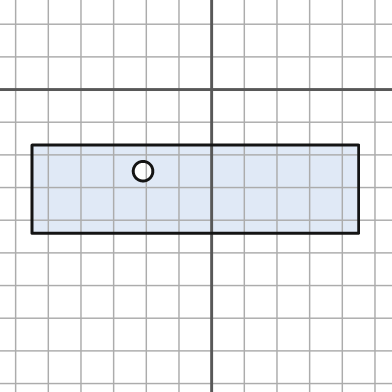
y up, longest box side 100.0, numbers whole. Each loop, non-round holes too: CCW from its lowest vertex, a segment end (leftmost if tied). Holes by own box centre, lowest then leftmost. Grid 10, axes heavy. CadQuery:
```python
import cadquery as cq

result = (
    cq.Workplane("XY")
    .moveTo(-55.0, -44.0)
    .lineTo(45.0, -44.0)
    .lineTo(45.0, -17.0)
    .lineTo(-55.0, -17.0)
    .close()
    .moveTo(-21.0, -25.0)
    .circle(3.0)
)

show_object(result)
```